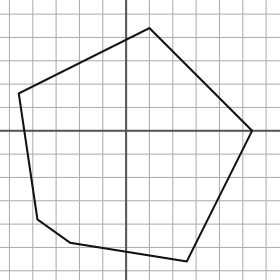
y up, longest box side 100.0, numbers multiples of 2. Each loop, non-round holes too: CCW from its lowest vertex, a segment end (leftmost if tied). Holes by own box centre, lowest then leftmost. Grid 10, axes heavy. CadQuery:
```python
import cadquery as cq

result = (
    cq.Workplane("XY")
    .moveTo(26.0, -56.0)
    .lineTo(54.0, 0.0)
    .lineTo(10.0, 44.0)
    .lineTo(-46.0, 16.0)
    .lineTo(-38.0, -38.0)
    .lineTo(-24.0, -48.0)
    .close()
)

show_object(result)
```